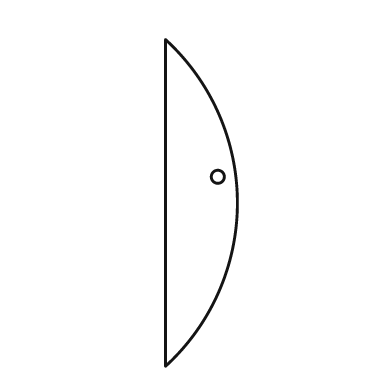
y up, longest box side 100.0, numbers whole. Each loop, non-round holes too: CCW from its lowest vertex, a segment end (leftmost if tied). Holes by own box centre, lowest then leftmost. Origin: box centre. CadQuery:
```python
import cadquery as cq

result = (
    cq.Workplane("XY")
    .moveTo(-11.0, -50.0)
    .threePointArc((11.0, 0.0), (-11.0, 50.0))
    .close()
    .moveTo(5.0, 8.0)
    .circle(2.0)
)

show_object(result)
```